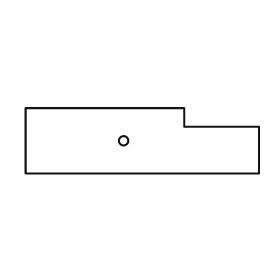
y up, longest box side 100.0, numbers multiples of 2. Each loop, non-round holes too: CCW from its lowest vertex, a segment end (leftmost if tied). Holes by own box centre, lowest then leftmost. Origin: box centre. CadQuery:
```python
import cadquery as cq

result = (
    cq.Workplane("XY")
    .moveTo(-50.0, -14.0)
    .lineTo(50.0, -14.0)
    .lineTo(50.0, 6.0)
    .lineTo(18.0, 6.0)
    .lineTo(18.0, 14.0)
    .lineTo(-50.0, 14.0)
    .close()
    .moveTo(-8.0, 0.0)
    .circle(2.0)
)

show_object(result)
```